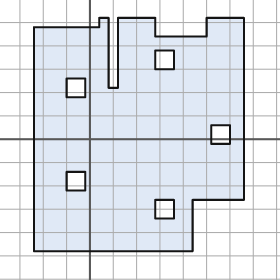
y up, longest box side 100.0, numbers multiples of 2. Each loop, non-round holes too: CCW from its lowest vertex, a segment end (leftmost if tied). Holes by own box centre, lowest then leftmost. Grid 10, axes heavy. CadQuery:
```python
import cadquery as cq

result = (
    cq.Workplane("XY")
    .moveTo(-24.0, -48.0)
    .lineTo(44.0, -48.0)
    .lineTo(44.0, -26.0)
    .lineTo(66.0, -26.0)
    .lineTo(66.0, 52.0)
    .lineTo(50.0, 52.0)
    .lineTo(50.0, 44.0)
    .lineTo(28.0, 44.0)
    .lineTo(28.0, 52.0)
    .lineTo(12.0, 52.0)
    .lineTo(12.0, 22.0)
    .lineTo(8.0, 22.0)
    .lineTo(8.0, 52.0)
    .lineTo(4.0, 52.0)
    .lineTo(4.0, 48.0)
    .lineTo(-24.0, 48.0)
    .close()
    .moveTo(28.0, -34.0)
    .lineTo(36.0, -34.0)
    .lineTo(36.0, -26.0)
    .lineTo(28.0, -26.0)
    .close()
    .moveTo(-10.0, -22.0)
    .lineTo(-2.0, -22.0)
    .lineTo(-2.0, -14.0)
    .lineTo(-10.0, -14.0)
    .close()
    .moveTo(52.0, -2.0)
    .lineTo(60.0, -2.0)
    .lineTo(60.0, 6.0)
    .lineTo(52.0, 6.0)
    .close()
    .moveTo(-10.0, 18.0)
    .lineTo(-2.0, 18.0)
    .lineTo(-2.0, 26.0)
    .lineTo(-10.0, 26.0)
    .close()
    .moveTo(28.0, 30.0)
    .lineTo(36.0, 30.0)
    .lineTo(36.0, 38.0)
    .lineTo(28.0, 38.0)
    .close()
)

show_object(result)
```